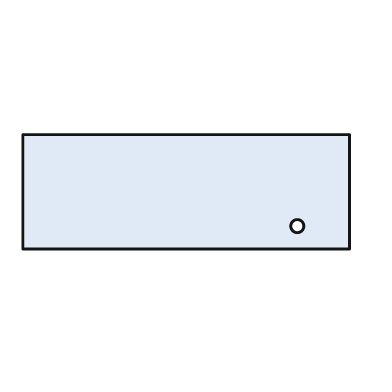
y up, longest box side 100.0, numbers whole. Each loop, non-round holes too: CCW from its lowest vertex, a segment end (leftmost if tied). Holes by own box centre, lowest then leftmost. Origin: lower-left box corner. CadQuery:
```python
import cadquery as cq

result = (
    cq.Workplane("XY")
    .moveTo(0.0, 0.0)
    .lineTo(100.0, 0.0)
    .lineTo(100.0, 35.0)
    .lineTo(0.0, 35.0)
    .close()
    .moveTo(84.0, 7.0)
    .circle(2.0)
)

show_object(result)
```